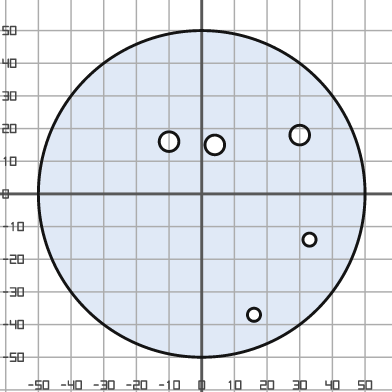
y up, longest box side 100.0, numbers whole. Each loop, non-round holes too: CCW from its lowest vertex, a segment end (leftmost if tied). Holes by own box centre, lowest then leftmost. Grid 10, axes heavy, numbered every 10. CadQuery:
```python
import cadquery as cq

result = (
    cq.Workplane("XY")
    .moveTo(0.0, 0.0)
    .circle(50.0)
    .moveTo(16.0, -37.0)
    .circle(2.0)
    .moveTo(33.0, -14.0)
    .circle(2.0)
    .moveTo(4.0, 15.0)
    .circle(3.0)
    .moveTo(-10.0, 16.0)
    .circle(3.0)
    .moveTo(30.0, 18.0)
    .circle(3.0)
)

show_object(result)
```